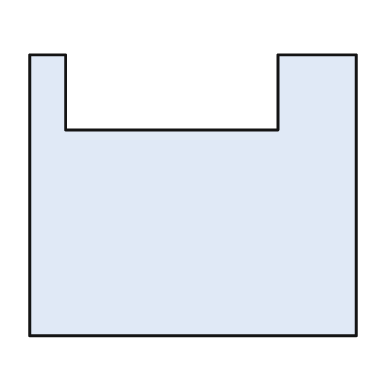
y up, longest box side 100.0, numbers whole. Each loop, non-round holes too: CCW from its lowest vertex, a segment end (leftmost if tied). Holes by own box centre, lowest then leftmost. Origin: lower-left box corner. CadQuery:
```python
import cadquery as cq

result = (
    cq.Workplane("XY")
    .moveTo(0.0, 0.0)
    .lineTo(100.0, 0.0)
    .lineTo(100.0, 86.0)
    .lineTo(76.0, 86.0)
    .lineTo(76.0, 63.0)
    .lineTo(11.0, 63.0)
    .lineTo(11.0, 86.0)
    .lineTo(0.0, 86.0)
    .close()
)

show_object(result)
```